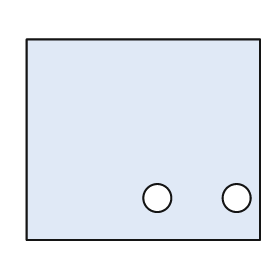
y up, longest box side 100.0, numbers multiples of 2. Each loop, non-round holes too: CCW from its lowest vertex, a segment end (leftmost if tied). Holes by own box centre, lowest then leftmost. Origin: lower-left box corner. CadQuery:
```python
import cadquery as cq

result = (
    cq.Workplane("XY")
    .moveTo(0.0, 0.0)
    .lineTo(100.0, 0.0)
    .lineTo(100.0, 86.0)
    .lineTo(0.0, 86.0)
    .close()
    .moveTo(56.0, 18.0)
    .circle(6.0)
    .moveTo(90.0, 18.0)
    .circle(6.0)
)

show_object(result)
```